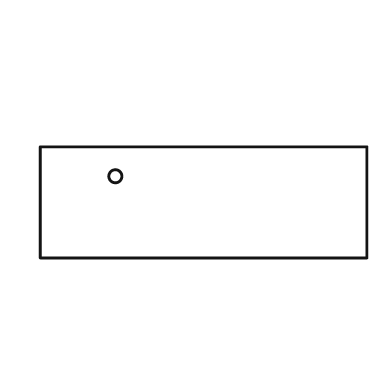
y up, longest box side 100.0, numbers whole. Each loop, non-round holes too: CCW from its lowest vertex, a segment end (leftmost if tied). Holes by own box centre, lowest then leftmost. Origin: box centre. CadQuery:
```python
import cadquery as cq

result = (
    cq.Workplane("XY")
    .moveTo(-50.0, -17.0)
    .lineTo(50.0, -17.0)
    .lineTo(50.0, 17.0)
    .lineTo(-50.0, 17.0)
    .close()
    .moveTo(-27.0, 8.0)
    .circle(2.0)
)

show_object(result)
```